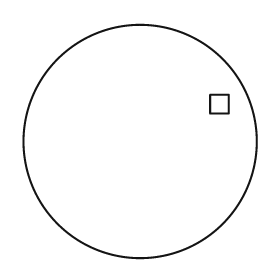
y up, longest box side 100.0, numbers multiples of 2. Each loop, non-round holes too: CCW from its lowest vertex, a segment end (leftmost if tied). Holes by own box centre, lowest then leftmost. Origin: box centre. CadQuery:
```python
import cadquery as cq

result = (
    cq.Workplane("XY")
    .moveTo(0.0, 0.0)
    .circle(50.0)
    .moveTo(30.0, 12.0)
    .lineTo(38.0, 12.0)
    .lineTo(38.0, 20.0)
    .lineTo(30.0, 20.0)
    .close()
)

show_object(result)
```